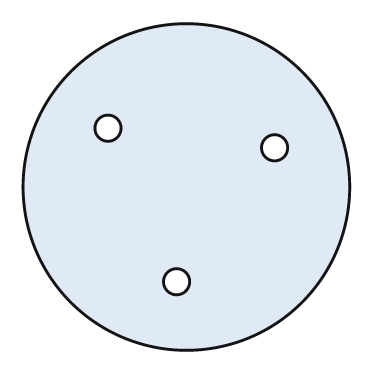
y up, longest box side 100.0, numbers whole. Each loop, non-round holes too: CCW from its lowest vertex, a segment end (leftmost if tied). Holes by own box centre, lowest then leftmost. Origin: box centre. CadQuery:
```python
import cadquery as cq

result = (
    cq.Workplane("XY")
    .moveTo(0.0, 0.0)
    .circle(50.0)
    .moveTo(-3.0, -29.0)
    .circle(4.0)
    .moveTo(27.0, 12.0)
    .circle(4.0)
    .moveTo(-24.0, 18.0)
    .circle(4.0)
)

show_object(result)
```